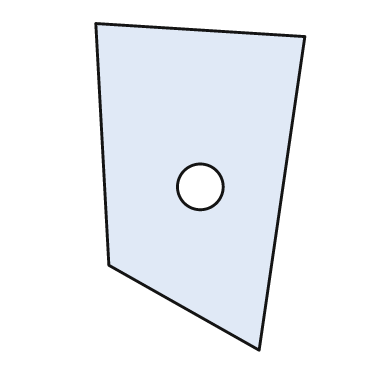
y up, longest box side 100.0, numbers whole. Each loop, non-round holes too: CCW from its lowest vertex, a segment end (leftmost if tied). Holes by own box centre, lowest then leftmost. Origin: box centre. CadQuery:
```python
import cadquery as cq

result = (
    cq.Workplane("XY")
    .moveTo(18.0, -50.0)
    .lineTo(32.0, 46.0)
    .lineTo(-32.0, 50.0)
    .lineTo(-28.0, -24.0)
    .close()
    .moveTo(0.0, 0.0)
    .circle(7.0)
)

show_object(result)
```